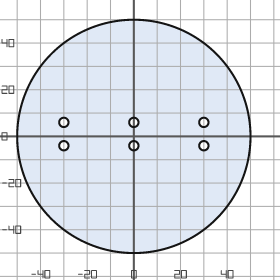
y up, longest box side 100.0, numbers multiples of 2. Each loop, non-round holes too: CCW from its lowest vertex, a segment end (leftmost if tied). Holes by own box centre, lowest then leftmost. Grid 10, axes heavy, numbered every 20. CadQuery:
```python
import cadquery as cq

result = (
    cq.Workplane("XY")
    .moveTo(0.0, 0.0)
    .circle(50.0)
    .moveTo(-30.0, -4.0)
    .circle(2.0)
    .moveTo(0.0, -4.0)
    .circle(2.0)
    .moveTo(30.0, -4.0)
    .circle(2.0)
    .moveTo(-30.0, 6.0)
    .circle(2.0)
    .moveTo(0.0, 6.0)
    .circle(2.0)
    .moveTo(30.0, 6.0)
    .circle(2.0)
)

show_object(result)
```